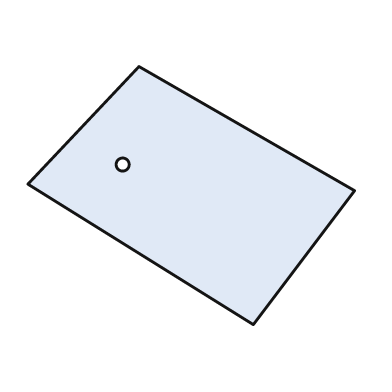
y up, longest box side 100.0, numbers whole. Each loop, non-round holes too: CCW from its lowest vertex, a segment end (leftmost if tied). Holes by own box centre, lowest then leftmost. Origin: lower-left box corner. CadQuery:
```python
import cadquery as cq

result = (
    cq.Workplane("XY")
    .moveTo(69.0, 0.0)
    .lineTo(100.0, 41.0)
    .lineTo(34.0, 79.0)
    .lineTo(0.0, 43.0)
    .close()
    .moveTo(29.0, 49.0)
    .circle(2.0)
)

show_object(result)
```